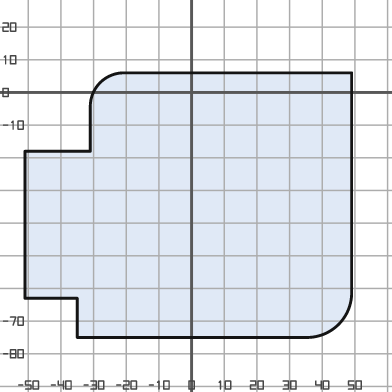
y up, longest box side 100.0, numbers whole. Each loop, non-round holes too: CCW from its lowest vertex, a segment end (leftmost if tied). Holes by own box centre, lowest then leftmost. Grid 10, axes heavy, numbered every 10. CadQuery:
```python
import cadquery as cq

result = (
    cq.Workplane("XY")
    .moveTo(-35.0, -75.0)
    .lineTo(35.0, -75.0)
    .threePointArc((45.0, -71.0), (49.0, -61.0))
    .lineTo(49.0, 6.0)
    .lineTo(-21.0, 6.0)
    .threePointArc((-28.0, 3.0), (-31.0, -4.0))
    .lineTo(-31.0, -18.0)
    .lineTo(-51.0, -18.0)
    .lineTo(-51.0, -63.0)
    .lineTo(-35.0, -63.0)
    .close()
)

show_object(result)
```